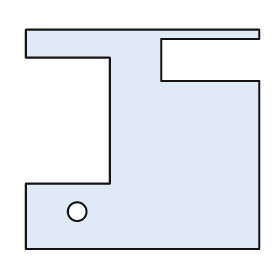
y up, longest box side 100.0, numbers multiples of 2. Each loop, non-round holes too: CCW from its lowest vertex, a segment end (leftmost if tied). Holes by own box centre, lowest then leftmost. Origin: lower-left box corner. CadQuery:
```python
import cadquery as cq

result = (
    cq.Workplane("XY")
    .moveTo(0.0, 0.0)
    .lineTo(100.0, 0.0)
    .lineTo(100.0, 72.0)
    .lineTo(58.0, 72.0)
    .lineTo(58.0, 90.0)
    .lineTo(100.0, 90.0)
    .lineTo(100.0, 94.0)
    .lineTo(0.0, 94.0)
    .lineTo(0.0, 82.0)
    .lineTo(36.0, 82.0)
    .lineTo(36.0, 28.0)
    .lineTo(0.0, 28.0)
    .close()
    .moveTo(22.0, 16.0)
    .circle(4.0)
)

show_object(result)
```